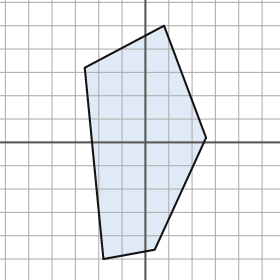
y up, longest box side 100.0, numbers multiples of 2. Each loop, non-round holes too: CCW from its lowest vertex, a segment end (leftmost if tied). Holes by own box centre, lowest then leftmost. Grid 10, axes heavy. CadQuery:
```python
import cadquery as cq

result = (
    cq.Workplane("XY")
    .moveTo(-18.0, -50.0)
    .lineTo(4.0, -46.0)
    .lineTo(26.0, 2.0)
    .lineTo(8.0, 50.0)
    .lineTo(-26.0, 32.0)
    .close()
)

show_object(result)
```